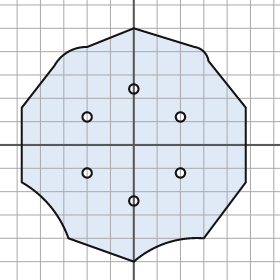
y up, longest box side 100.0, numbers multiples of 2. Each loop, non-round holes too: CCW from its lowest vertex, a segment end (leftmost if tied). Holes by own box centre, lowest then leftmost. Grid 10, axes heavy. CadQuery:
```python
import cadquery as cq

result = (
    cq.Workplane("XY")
    .moveTo(0.0, -50.0)
    .threePointArc((14.0, -42.0), (30.0, -40.0))
    .lineTo(48.0, -16.0)
    .lineTo(48.0, 16.0)
    .lineTo(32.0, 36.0)
    .threePointArc((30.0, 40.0), (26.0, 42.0))
    .lineTo(0.0, 50.0)
    .lineTo(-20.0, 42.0)
    .threePointArc((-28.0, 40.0), (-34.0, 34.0))
    .lineTo(-48.0, 16.0)
    .lineTo(-48.0, -16.0)
    .threePointArc((-36.0, -26.0), (-28.0, -40.0))
    .close()
    .moveTo(0.0, -24.0)
    .circle(2.0)
    .moveTo(-20.0, -12.0)
    .circle(2.0)
    .moveTo(20.0, -12.0)
    .circle(2.0)
    .moveTo(-20.0, 12.0)
    .circle(2.0)
    .moveTo(20.0, 12.0)
    .circle(2.0)
    .moveTo(0.0, 24.0)
    .circle(2.0)
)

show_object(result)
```